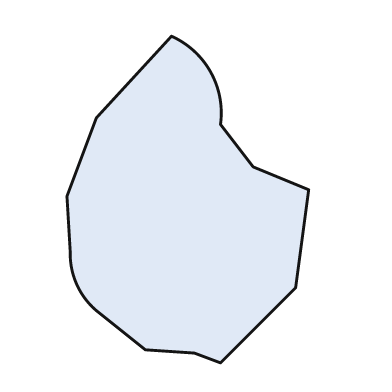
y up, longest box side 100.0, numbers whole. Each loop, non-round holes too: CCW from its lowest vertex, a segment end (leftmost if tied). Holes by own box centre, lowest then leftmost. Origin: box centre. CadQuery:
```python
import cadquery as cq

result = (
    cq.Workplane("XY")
    .moveTo(10.0, -50.0)
    .lineTo(33.0, -27.0)
    .lineTo(37.0, 3.0)
    .lineTo(20.0, 10.0)
    .lineTo(10.0, 23.0)
    .threePointArc((7.0, 39.0), (-5.0, 50.0))
    .lineTo(-28.0, 25.0)
    .lineTo(-37.0, 1.0)
    .lineTo(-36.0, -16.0)
    .threePointArc((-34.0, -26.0), (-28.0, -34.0))
    .lineTo(-13.0, -46.0)
    .lineTo(2.0, -47.0)
    .close()
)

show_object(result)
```